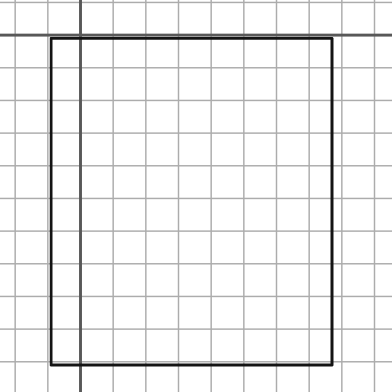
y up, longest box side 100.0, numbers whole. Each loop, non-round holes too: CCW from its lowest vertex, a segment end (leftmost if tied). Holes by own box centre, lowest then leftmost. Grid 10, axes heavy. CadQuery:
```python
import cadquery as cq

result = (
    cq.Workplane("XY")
    .moveTo(-9.0, -101.0)
    .lineTo(77.0, -101.0)
    .lineTo(77.0, -1.0)
    .lineTo(-9.0, -1.0)
    .close()
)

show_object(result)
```